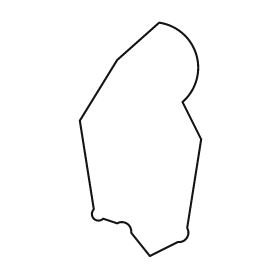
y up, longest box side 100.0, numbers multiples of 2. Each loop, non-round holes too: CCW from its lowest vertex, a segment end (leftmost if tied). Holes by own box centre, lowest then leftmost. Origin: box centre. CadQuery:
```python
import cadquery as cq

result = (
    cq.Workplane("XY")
    .moveTo(4.0, -50.0)
    .lineTo(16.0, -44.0)
    .threePointArc((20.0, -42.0), (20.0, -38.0))
    .lineTo(26.0, 0.0)
    .lineTo(18.0, 16.0)
    .threePointArc((24.0, 36.0), (8.0, 50.0))
    .lineTo(-10.0, 34.0)
    .lineTo(-26.0, 8.0)
    .lineTo(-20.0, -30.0)
    .threePointArc((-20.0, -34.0), (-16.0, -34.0))
    .lineTo(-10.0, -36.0)
    .threePointArc((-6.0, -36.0), (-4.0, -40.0))
    .close()
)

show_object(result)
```